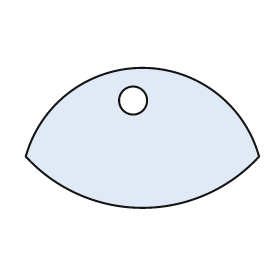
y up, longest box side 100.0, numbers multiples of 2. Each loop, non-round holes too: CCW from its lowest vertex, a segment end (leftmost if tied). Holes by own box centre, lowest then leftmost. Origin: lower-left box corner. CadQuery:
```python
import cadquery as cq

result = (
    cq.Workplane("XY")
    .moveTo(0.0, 22.0)
    .threePointArc((50.0, 0.0), (100.0, 22.0))
    .threePointArc((50.0, 60.0), (0.0, 22.0))
    .close()
    .moveTo(46.0, 46.0)
    .circle(6.0)
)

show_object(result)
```